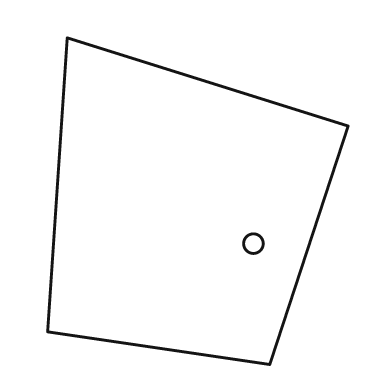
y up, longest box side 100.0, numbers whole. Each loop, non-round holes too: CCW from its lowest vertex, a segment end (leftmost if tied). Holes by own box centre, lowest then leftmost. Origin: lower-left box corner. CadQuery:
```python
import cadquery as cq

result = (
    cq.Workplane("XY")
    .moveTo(68.0, 0.0)
    .lineTo(92.0, 73.0)
    .lineTo(6.0, 100.0)
    .lineTo(0.0, 10.0)
    .close()
    .moveTo(63.0, 37.0)
    .circle(3.0)
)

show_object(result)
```